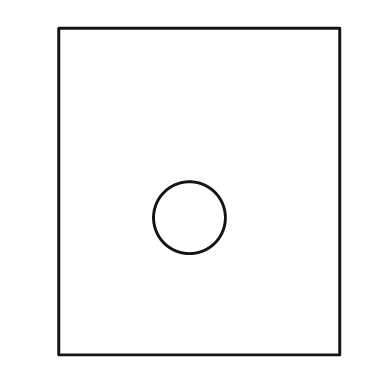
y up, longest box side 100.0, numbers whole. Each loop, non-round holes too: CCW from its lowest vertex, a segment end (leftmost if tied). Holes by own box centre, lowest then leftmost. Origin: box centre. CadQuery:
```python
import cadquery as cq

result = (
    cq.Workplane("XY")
    .moveTo(-43.0, -50.0)
    .lineTo(43.0, -50.0)
    .lineTo(43.0, 50.0)
    .lineTo(-43.0, 50.0)
    .close()
    .moveTo(-3.0, -8.0)
    .circle(11.0)
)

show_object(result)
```